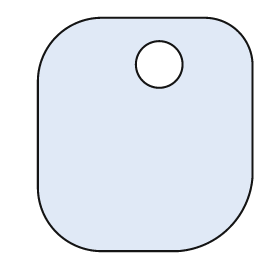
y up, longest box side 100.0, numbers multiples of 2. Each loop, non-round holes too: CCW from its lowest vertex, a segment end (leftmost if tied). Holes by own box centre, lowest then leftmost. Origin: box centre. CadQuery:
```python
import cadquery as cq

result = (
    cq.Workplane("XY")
    .moveTo(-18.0, -50.0)
    .lineTo(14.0, -50.0)
    .threePointArc((36.0, -40.0), (46.0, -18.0))
    .lineTo(46.0, 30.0)
    .threePointArc((40.0, 44.0), (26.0, 50.0))
    .lineTo(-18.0, 50.0)
    .threePointArc((-38.0, 42.0), (-46.0, 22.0))
    .lineTo(-46.0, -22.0)
    .threePointArc((-38.0, -42.0), (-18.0, -50.0))
    .close()
    .moveTo(6.0, 30.0)
    .circle(10.0)
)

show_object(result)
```